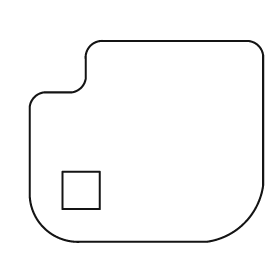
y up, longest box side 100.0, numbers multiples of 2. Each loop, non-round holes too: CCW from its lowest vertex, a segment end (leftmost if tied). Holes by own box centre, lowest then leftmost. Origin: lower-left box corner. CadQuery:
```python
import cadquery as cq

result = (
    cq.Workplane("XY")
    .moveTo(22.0, 0.0)
    .lineTo(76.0, 0.0)
    .threePointArc((92.0, 8.0), (100.0, 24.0))
    .lineTo(100.0, 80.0)
    .threePointArc((98.0, 84.0), (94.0, 86.0))
    .lineTo(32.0, 86.0)
    .threePointArc((26.0, 84.0), (24.0, 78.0))
    .lineTo(24.0, 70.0)
    .threePointArc((22.0, 66.0), (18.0, 64.0))
    .lineTo(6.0, 64.0)
    .threePointArc((2.0, 62.0), (0.0, 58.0))
    .lineTo(0.0, 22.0)
    .threePointArc((6.0, 6.0), (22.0, 0.0))
    .close()
    .moveTo(14.0, 14.0)
    .lineTo(30.0, 14.0)
    .lineTo(30.0, 30.0)
    .lineTo(14.0, 30.0)
    .close()
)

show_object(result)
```